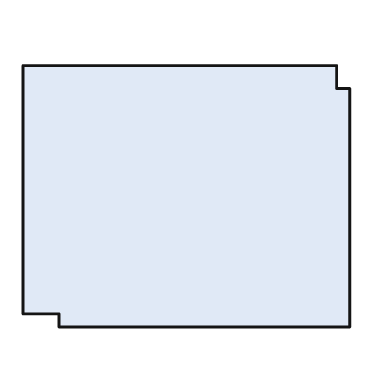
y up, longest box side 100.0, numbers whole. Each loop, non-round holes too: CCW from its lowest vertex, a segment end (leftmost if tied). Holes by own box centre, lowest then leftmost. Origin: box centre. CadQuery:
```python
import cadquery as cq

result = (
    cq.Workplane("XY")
    .moveTo(-39.0, -40.0)
    .lineTo(50.0, -40.0)
    .lineTo(50.0, 33.0)
    .lineTo(46.0, 33.0)
    .lineTo(46.0, 40.0)
    .lineTo(-50.0, 40.0)
    .lineTo(-50.0, -36.0)
    .lineTo(-39.0, -36.0)
    .close()
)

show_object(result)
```